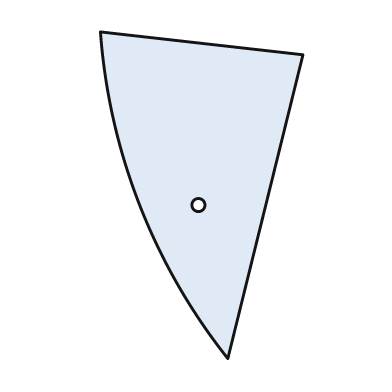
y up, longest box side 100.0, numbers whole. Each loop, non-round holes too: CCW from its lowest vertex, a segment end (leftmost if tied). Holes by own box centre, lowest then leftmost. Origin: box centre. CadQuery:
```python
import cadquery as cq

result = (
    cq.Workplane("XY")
    .moveTo(8.0, -50.0)
    .lineTo(31.0, 43.0)
    .lineTo(-31.0, 50.0)
    .threePointArc((-19.0, -3.0), (8.0, -50.0))
    .close()
    .moveTo(-1.0, -3.0)
    .circle(2.0)
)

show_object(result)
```